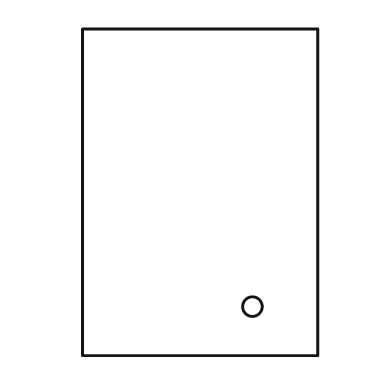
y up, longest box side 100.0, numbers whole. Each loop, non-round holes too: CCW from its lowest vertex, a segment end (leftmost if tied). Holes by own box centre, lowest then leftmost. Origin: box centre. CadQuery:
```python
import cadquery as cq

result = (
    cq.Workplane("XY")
    .moveTo(-36.0, -50.0)
    .lineTo(36.0, -50.0)
    .lineTo(36.0, 50.0)
    .lineTo(-36.0, 50.0)
    .close()
    .moveTo(16.0, -35.0)
    .circle(3.0)
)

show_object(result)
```